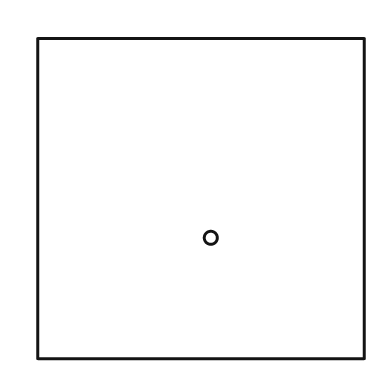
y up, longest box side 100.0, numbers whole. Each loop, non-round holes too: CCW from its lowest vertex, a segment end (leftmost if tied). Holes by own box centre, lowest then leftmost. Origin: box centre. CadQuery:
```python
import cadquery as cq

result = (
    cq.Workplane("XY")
    .moveTo(-50.0, -49.0)
    .lineTo(50.0, -49.0)
    .lineTo(50.0, 49.0)
    .lineTo(-50.0, 49.0)
    .close()
    .moveTo(3.0, -12.0)
    .circle(2.0)
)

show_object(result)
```